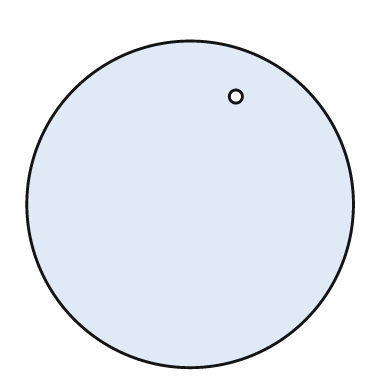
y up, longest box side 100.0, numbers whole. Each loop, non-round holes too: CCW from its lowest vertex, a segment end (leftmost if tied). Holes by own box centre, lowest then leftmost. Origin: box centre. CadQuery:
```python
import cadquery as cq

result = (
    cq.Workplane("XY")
    .moveTo(0.0, 0.0)
    .circle(50.0)
    .moveTo(14.0, 33.0)
    .circle(2.0)
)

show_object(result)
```